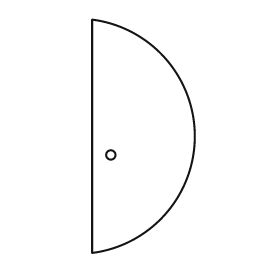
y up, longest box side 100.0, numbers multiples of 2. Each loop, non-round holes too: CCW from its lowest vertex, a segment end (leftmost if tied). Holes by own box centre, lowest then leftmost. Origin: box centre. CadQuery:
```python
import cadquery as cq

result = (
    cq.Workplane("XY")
    .moveTo(-22.0, -50.0)
    .threePointArc((22.0, 0.0), (-22.0, 50.0))
    .close()
    .moveTo(-14.0, -8.0)
    .circle(2.0)
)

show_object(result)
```